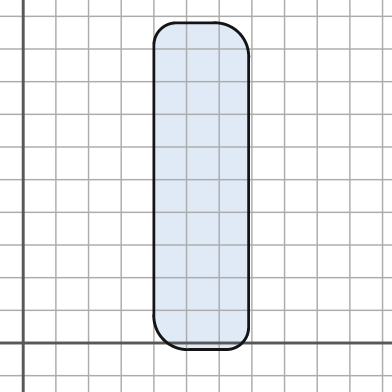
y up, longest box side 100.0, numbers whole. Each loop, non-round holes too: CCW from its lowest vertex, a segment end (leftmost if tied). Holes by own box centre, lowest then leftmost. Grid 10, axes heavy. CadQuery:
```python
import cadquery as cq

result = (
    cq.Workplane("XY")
    .moveTo(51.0, -2.0)
    .lineTo(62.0, -2.0)
    .threePointArc((67.0, 0.0), (69.0, 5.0))
    .lineTo(69.0, 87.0)
    .threePointArc((66.0, 95.0), (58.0, 98.0))
    .lineTo(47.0, 98.0)
    .threePointArc((42.0, 96.0), (40.0, 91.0))
    .lineTo(40.0, 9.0)
    .threePointArc((43.0, 1.0), (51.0, -2.0))
    .close()
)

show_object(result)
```